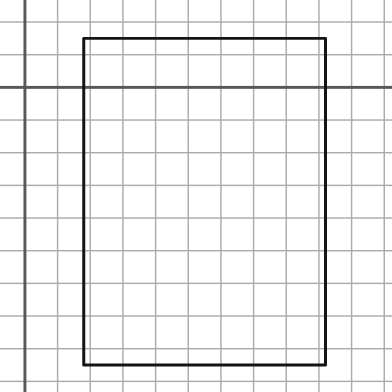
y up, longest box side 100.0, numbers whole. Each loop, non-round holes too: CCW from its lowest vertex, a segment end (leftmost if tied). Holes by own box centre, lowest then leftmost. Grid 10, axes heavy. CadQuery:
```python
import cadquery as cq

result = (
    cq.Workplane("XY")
    .moveTo(18.0, -85.0)
    .lineTo(92.0, -85.0)
    .lineTo(92.0, 15.0)
    .lineTo(18.0, 15.0)
    .close()
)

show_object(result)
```